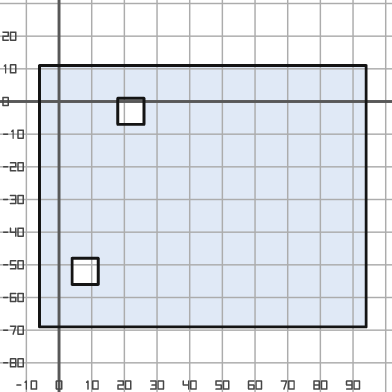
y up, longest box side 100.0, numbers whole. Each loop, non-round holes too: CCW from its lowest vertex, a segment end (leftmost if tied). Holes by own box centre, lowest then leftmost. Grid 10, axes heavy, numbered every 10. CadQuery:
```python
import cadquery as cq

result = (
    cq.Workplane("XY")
    .moveTo(-6.0, -69.0)
    .lineTo(94.0, -69.0)
    .lineTo(94.0, 11.0)
    .lineTo(-6.0, 11.0)
    .close()
    .moveTo(4.0, -56.0)
    .lineTo(12.0, -56.0)
    .lineTo(12.0, -48.0)
    .lineTo(4.0, -48.0)
    .close()
    .moveTo(18.0, -7.0)
    .lineTo(26.0, -7.0)
    .lineTo(26.0, 1.0)
    .lineTo(18.0, 1.0)
    .close()
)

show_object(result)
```